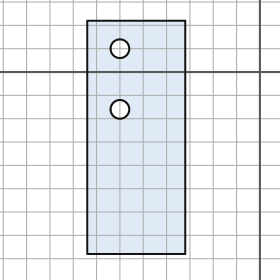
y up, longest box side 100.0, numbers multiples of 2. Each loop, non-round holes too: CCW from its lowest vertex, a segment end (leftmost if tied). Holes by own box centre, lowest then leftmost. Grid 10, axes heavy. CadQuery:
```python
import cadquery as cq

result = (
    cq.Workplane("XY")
    .moveTo(-74.0, -78.0)
    .lineTo(-32.0, -78.0)
    .lineTo(-32.0, 22.0)
    .lineTo(-74.0, 22.0)
    .close()
    .moveTo(-60.0, -16.0)
    .circle(4.0)
    .moveTo(-60.0, 10.0)
    .circle(4.0)
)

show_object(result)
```